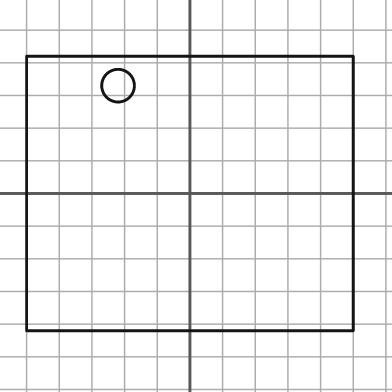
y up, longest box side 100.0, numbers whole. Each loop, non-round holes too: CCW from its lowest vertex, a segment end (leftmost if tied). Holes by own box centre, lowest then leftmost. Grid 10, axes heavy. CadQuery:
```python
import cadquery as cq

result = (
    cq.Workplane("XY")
    .moveTo(-50.0, -42.0)
    .lineTo(50.0, -42.0)
    .lineTo(50.0, 42.0)
    .lineTo(-50.0, 42.0)
    .close()
    .moveTo(-22.0, 33.0)
    .circle(5.0)
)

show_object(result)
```